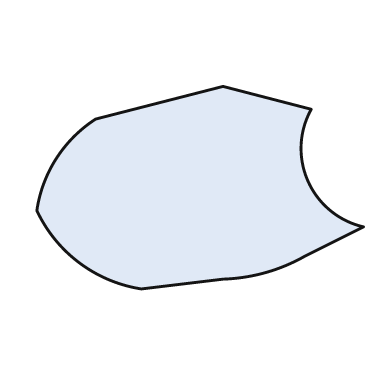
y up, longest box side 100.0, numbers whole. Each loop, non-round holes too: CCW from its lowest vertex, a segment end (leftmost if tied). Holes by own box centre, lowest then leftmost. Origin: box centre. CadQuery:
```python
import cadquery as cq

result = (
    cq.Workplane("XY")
    .moveTo(-18.0, -31.0)
    .lineTo(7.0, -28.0)
    .threePointArc((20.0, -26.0), (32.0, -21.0))
    .lineTo(50.0, -12.0)
    .threePointArc((33.0, 2.0), (34.0, 24.0))
    .lineTo(7.0, 31.0)
    .lineTo(-32.0, 21.0)
    .threePointArc((-44.0, 9.0), (-50.0, -7.0))
    .threePointArc((-37.0, -23.0), (-18.0, -31.0))
    .close()
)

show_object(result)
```